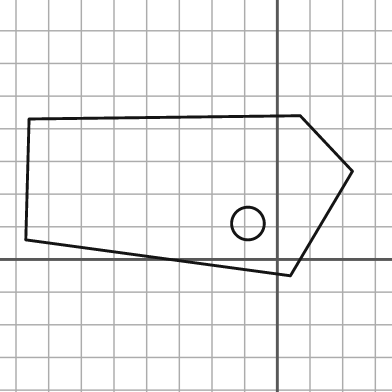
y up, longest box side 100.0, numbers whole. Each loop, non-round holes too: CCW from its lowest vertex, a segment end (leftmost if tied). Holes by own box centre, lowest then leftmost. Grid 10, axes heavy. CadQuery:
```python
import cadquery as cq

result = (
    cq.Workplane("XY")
    .moveTo(4.0, -5.0)
    .lineTo(23.0, 27.0)
    .lineTo(7.0, 44.0)
    .lineTo(-76.0, 43.0)
    .lineTo(-77.0, 6.0)
    .close()
    .moveTo(-9.0, 11.0)
    .circle(5.0)
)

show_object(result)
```